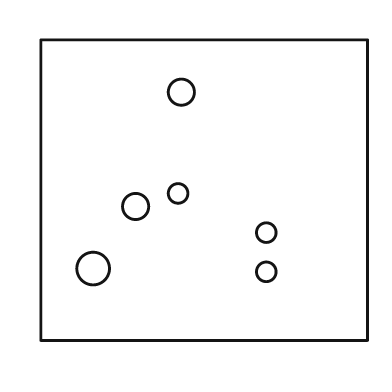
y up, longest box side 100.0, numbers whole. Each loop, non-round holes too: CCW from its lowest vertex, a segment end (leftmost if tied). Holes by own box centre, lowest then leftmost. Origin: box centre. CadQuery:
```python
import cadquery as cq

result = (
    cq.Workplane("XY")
    .moveTo(-50.0, -46.0)
    .lineTo(50.0, -46.0)
    .lineTo(50.0, 46.0)
    .lineTo(-50.0, 46.0)
    .close()
    .moveTo(19.0, -25.0)
    .circle(3.0)
    .moveTo(-34.0, -24.0)
    .circle(5.0)
    .moveTo(19.0, -13.0)
    .circle(3.0)
    .moveTo(-21.0, -5.0)
    .circle(4.0)
    .moveTo(-8.0, -1.0)
    .circle(3.0)
    .moveTo(-7.0, 30.0)
    .circle(4.0)
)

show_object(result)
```